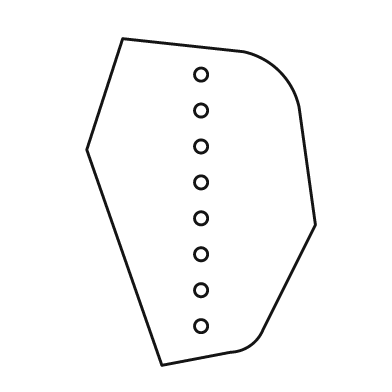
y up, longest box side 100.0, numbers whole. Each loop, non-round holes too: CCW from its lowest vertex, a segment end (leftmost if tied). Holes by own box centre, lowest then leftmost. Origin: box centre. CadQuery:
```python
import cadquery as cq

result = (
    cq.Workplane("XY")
    .moveTo(-12.0, -50.0)
    .lineTo(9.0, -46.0)
    .threePointArc((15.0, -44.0), (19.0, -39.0))
    .lineTo(35.0, -7.0)
    .lineTo(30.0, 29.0)
    .threePointArc((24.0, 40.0), (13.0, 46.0))
    .lineTo(-24.0, 50.0)
    .lineTo(-35.0, 16.0)
    .close()
    .moveTo(0.0, -38.0)
    .circle(2.0)
    .moveTo(0.0, -27.0)
    .circle(2.0)
    .moveTo(0.0, -16.0)
    .circle(2.0)
    .moveTo(0.0, -5.0)
    .circle(2.0)
    .moveTo(0.0, 6.0)
    .circle(2.0)
    .moveTo(0.0, 17.0)
    .circle(2.0)
    .moveTo(0.0, 28.0)
    .circle(2.0)
    .moveTo(0.0, 39.0)
    .circle(2.0)
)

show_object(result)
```